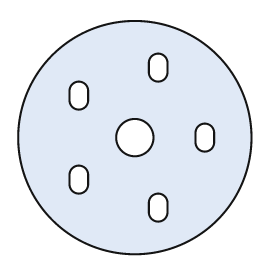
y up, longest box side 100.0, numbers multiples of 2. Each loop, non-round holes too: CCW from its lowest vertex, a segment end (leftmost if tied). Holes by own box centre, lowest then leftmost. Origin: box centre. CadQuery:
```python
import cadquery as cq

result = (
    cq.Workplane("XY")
    .moveTo(0.0, 0.0)
    .circle(50.0)
    .moveTo(6.0, -32.0)
    .threePointArc((10.0, -36.0), (14.0, -32.0))
    .lineTo(14.0, -28.0)
    .threePointArc((10.0, -24.0), (6.0, -28.0))
    .close()
    .moveTo(-28.0, -20.0)
    .threePointArc((-24.0, -24.0), (-20.0, -20.0))
    .lineTo(-20.0, -16.0)
    .threePointArc((-24.0, -12.0), (-28.0, -16.0))
    .close()
    .moveTo(0.0, 0.0)
    .circle(8.0)
    .moveTo(26.0, -2.0)
    .threePointArc((30.0, -6.0), (34.0, -2.0))
    .lineTo(34.0, 2.0)
    .threePointArc((30.0, 6.0), (26.0, 2.0))
    .close()
    .moveTo(-28.0, 16.0)
    .threePointArc((-24.0, 12.0), (-20.0, 16.0))
    .lineTo(-20.0, 20.0)
    .threePointArc((-24.0, 24.0), (-28.0, 20.0))
    .close()
    .moveTo(6.0, 28.0)
    .threePointArc((10.0, 24.0), (14.0, 28.0))
    .lineTo(14.0, 32.0)
    .threePointArc((10.0, 36.0), (6.0, 32.0))
    .close()
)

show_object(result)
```